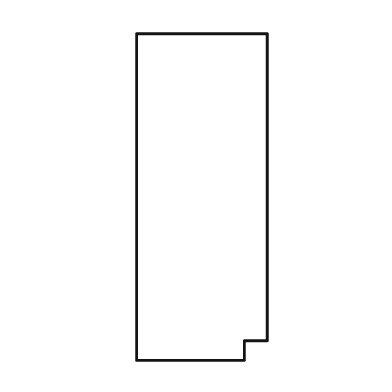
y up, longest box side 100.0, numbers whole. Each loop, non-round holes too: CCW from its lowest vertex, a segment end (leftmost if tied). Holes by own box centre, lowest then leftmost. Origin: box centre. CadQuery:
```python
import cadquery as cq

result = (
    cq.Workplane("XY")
    .moveTo(-20.0, -50.0)
    .lineTo(13.0, -50.0)
    .lineTo(13.0, -44.0)
    .lineTo(20.0, -44.0)
    .lineTo(20.0, 50.0)
    .lineTo(-20.0, 50.0)
    .close()
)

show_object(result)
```